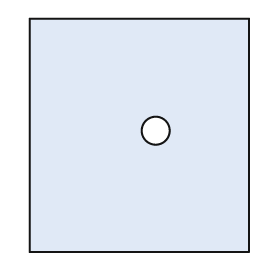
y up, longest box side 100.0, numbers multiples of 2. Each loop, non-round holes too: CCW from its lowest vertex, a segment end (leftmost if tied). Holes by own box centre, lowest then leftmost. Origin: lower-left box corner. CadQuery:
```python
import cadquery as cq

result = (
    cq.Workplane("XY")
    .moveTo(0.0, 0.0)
    .lineTo(94.0, 0.0)
    .lineTo(94.0, 100.0)
    .lineTo(0.0, 100.0)
    .close()
    .moveTo(54.0, 52.0)
    .circle(6.0)
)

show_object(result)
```